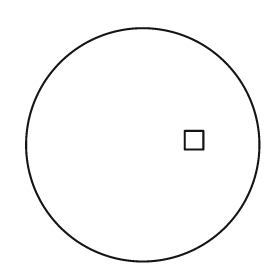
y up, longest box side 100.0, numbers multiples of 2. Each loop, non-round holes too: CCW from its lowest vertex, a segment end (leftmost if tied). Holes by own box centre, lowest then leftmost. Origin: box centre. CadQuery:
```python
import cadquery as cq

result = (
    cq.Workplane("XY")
    .moveTo(0.0, 0.0)
    .circle(50.0)
    .moveTo(18.0, -2.0)
    .lineTo(26.0, -2.0)
    .lineTo(26.0, 6.0)
    .lineTo(18.0, 6.0)
    .close()
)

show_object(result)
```